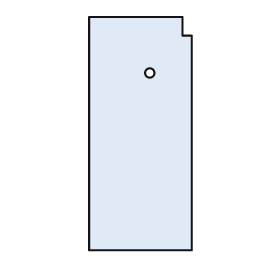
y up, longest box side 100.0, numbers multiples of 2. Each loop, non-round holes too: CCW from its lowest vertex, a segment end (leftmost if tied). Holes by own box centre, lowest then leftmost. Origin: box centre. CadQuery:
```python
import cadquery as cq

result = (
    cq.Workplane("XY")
    .moveTo(-22.0, -50.0)
    .lineTo(22.0, -50.0)
    .lineTo(22.0, 42.0)
    .lineTo(18.0, 42.0)
    .lineTo(18.0, 50.0)
    .lineTo(-22.0, 50.0)
    .close()
    .moveTo(4.0, 26.0)
    .circle(2.0)
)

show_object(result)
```